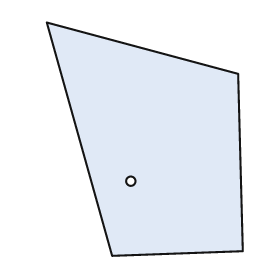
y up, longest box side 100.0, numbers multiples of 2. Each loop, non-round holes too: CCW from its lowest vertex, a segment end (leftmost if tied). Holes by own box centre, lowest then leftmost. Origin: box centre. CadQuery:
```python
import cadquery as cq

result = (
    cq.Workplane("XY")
    .moveTo(-14.0, -50.0)
    .lineTo(42.0, -48.0)
    .lineTo(40.0, 28.0)
    .lineTo(-42.0, 50.0)
    .close()
    .moveTo(-6.0, -18.0)
    .circle(2.0)
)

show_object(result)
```